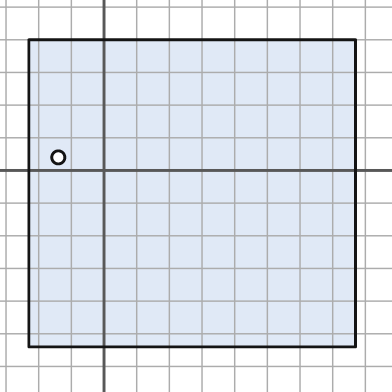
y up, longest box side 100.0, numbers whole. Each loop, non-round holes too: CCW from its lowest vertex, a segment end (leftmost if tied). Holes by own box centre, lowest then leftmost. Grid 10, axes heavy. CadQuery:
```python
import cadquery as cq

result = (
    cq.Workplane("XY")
    .moveTo(-23.0, -54.0)
    .lineTo(77.0, -54.0)
    .lineTo(77.0, 40.0)
    .lineTo(-23.0, 40.0)
    .close()
    .moveTo(-14.0, 4.0)
    .circle(2.0)
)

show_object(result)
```